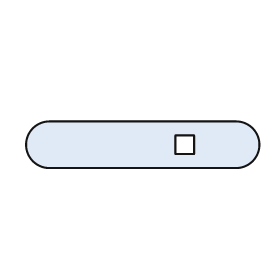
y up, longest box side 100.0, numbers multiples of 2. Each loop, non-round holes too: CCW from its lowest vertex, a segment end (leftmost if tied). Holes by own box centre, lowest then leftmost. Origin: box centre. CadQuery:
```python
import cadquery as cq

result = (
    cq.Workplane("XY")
    .moveTo(-40.0, -10.0)
    .lineTo(40.0, -10.0)
    .threePointArc((50.0, 0.0), (40.0, 10.0))
    .lineTo(-40.0, 10.0)
    .threePointArc((-50.0, 0.0), (-40.0, -10.0))
    .close()
    .moveTo(14.0, -4.0)
    .lineTo(22.0, -4.0)
    .lineTo(22.0, 4.0)
    .lineTo(14.0, 4.0)
    .close()
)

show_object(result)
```